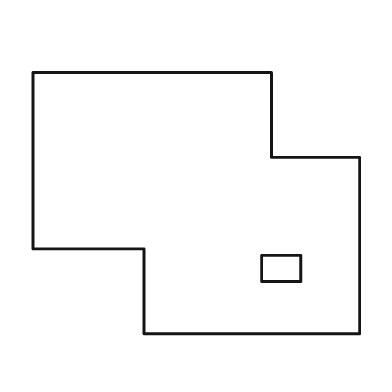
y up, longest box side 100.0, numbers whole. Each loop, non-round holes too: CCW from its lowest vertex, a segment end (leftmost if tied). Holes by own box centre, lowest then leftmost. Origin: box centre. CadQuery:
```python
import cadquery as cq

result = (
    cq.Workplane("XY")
    .moveTo(-16.0, -40.0)
    .lineTo(50.0, -40.0)
    .lineTo(50.0, 14.0)
    .lineTo(23.0, 14.0)
    .lineTo(23.0, 40.0)
    .lineTo(-50.0, 40.0)
    .lineTo(-50.0, -14.0)
    .lineTo(-16.0, -14.0)
    .close()
    .moveTo(20.0, -24.0)
    .lineTo(32.0, -24.0)
    .lineTo(32.0, -16.0)
    .lineTo(20.0, -16.0)
    .close()
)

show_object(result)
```